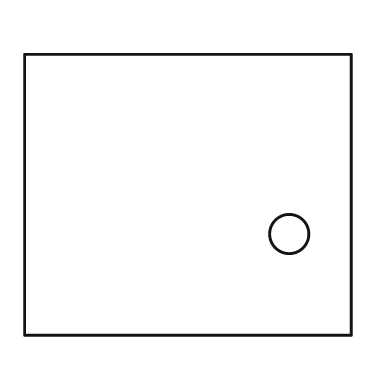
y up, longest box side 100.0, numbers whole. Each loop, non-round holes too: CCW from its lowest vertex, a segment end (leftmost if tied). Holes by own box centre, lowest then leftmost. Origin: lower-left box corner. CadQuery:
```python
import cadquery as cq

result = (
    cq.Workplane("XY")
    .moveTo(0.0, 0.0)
    .lineTo(100.0, 0.0)
    .lineTo(100.0, 86.0)
    .lineTo(0.0, 86.0)
    .close()
    .moveTo(81.0, 31.0)
    .circle(6.0)
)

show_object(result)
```